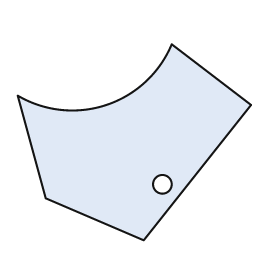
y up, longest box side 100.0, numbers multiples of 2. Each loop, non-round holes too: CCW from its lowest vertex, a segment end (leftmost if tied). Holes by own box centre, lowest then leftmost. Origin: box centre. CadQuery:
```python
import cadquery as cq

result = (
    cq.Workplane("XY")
    .moveTo(4.0, -42.0)
    .lineTo(50.0, 16.0)
    .lineTo(16.0, 42.0)
    .threePointArc((-12.0, 16.0), (-50.0, 20.0))
    .lineTo(-38.0, -24.0)
    .close()
    .moveTo(12.0, -18.0)
    .circle(4.0)
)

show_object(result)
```